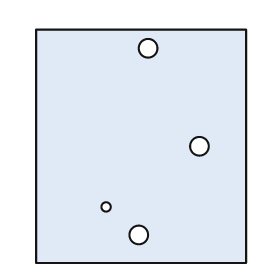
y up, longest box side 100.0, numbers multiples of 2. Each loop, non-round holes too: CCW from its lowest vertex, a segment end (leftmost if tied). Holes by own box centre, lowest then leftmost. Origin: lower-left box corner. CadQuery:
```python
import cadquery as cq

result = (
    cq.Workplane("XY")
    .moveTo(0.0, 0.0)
    .lineTo(90.0, 0.0)
    .lineTo(90.0, 100.0)
    .lineTo(0.0, 100.0)
    .close()
    .moveTo(44.0, 12.0)
    .circle(4.0)
    .moveTo(30.0, 24.0)
    .circle(2.0)
    .moveTo(70.0, 50.0)
    .circle(4.0)
    .moveTo(48.0, 92.0)
    .circle(4.0)
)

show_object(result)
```